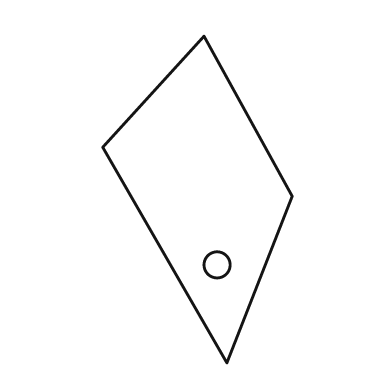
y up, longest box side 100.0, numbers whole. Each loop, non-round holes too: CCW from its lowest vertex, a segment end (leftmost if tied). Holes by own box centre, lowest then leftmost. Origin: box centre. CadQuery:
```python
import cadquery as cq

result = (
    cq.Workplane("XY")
    .moveTo(9.0, -50.0)
    .lineTo(29.0, 1.0)
    .lineTo(2.0, 50.0)
    .lineTo(-29.0, 16.0)
    .close()
    .moveTo(6.0, -20.0)
    .circle(4.0)
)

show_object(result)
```